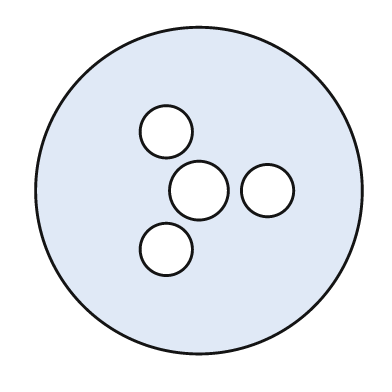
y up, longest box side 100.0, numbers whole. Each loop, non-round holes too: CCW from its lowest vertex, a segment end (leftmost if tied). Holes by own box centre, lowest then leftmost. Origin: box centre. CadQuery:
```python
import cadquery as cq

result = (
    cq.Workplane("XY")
    .moveTo(0.0, 0.0)
    .circle(50.0)
    .moveTo(-10.0, -18.0)
    .circle(8.0)
    .moveTo(0.0, 0.0)
    .circle(9.0)
    .moveTo(21.0, 0.0)
    .circle(8.0)
    .moveTo(-10.0, 18.0)
    .circle(8.0)
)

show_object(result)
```